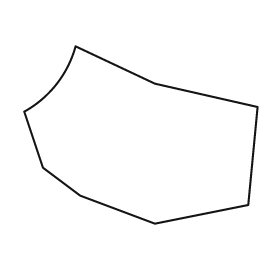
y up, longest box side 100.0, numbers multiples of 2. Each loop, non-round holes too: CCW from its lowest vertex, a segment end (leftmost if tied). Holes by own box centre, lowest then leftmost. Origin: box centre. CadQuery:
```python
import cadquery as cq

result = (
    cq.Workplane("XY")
    .moveTo(6.0, -38.0)
    .lineTo(46.0, -30.0)
    .lineTo(50.0, 12.0)
    .lineTo(6.0, 22.0)
    .lineTo(-28.0, 38.0)
    .threePointArc((-36.0, 22.0), (-50.0, 10.0))
    .lineTo(-42.0, -14.0)
    .lineTo(-26.0, -26.0)
    .close()
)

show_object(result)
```